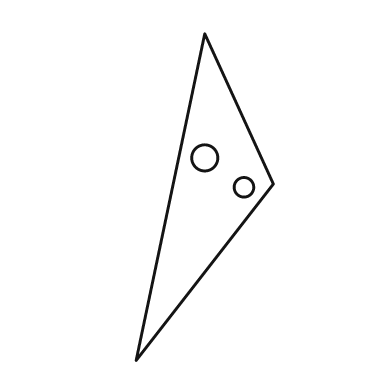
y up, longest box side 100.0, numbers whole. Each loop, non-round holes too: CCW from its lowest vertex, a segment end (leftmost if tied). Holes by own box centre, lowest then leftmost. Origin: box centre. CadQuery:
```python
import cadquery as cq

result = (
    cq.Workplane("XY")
    .moveTo(-21.0, -50.0)
    .lineTo(21.0, 4.0)
    .lineTo(0.0, 50.0)
    .close()
    .moveTo(12.0, 3.0)
    .circle(3.0)
    .moveTo(0.0, 12.0)
    .circle(4.0)
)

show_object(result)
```